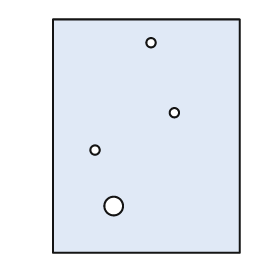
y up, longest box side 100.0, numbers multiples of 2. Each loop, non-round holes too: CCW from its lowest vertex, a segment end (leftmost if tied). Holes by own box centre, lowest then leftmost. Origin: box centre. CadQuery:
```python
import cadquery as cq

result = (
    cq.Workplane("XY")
    .moveTo(-40.0, -50.0)
    .lineTo(40.0, -50.0)
    .lineTo(40.0, 50.0)
    .lineTo(-40.0, 50.0)
    .close()
    .moveTo(-14.0, -30.0)
    .circle(4.0)
    .moveTo(-22.0, -6.0)
    .circle(2.0)
    .moveTo(12.0, 10.0)
    .circle(2.0)
    .moveTo(2.0, 40.0)
    .circle(2.0)
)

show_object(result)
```